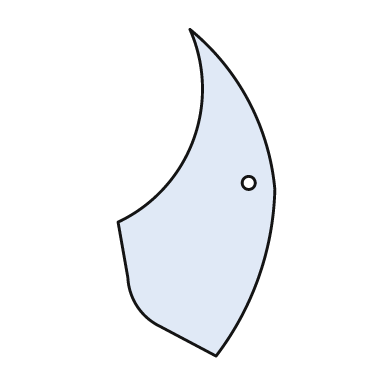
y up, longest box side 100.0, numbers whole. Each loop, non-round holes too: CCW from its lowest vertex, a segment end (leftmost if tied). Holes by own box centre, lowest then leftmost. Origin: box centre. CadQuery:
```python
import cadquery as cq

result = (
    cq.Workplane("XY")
    .moveTo(6.0, -50.0)
    .threePointArc((19.0, -26.0), (24.0, 1.0))
    .threePointArc((16.0, 28.0), (-2.0, 50.0))
    .threePointArc((-1.0, 16.0), (-24.0, -9.0))
    .lineTo(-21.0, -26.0)
    .threePointArc((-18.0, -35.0), (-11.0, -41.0))
    .close()
    .moveTo(16.0, 3.0)
    .circle(2.0)
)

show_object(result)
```